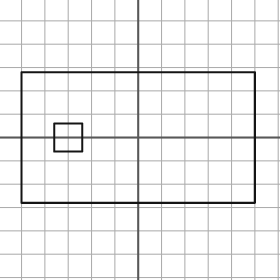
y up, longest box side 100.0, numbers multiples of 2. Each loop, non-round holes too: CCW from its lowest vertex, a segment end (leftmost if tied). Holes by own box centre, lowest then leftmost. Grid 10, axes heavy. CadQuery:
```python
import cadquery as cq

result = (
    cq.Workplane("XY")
    .moveTo(-50.0, -28.0)
    .lineTo(50.0, -28.0)
    .lineTo(50.0, 28.0)
    .lineTo(-50.0, 28.0)
    .close()
    .moveTo(-36.0, -6.0)
    .lineTo(-24.0, -6.0)
    .lineTo(-24.0, 6.0)
    .lineTo(-36.0, 6.0)
    .close()
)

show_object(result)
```